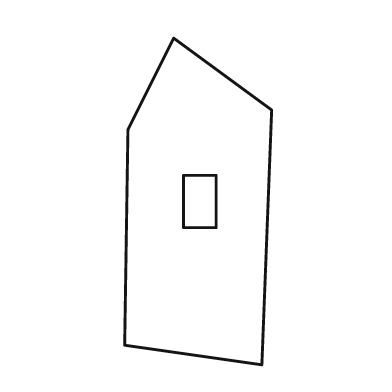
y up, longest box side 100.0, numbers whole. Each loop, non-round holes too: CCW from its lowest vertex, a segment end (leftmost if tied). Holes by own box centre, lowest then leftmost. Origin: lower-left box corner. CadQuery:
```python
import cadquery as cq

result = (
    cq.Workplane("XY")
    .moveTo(42.0, 0.0)
    .lineTo(45.0, 78.0)
    .lineTo(15.0, 100.0)
    .lineTo(1.0, 72.0)
    .lineTo(0.0, 6.0)
    .close()
    .moveTo(18.0, 42.0)
    .lineTo(28.0, 42.0)
    .lineTo(28.0, 58.0)
    .lineTo(18.0, 58.0)
    .close()
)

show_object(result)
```